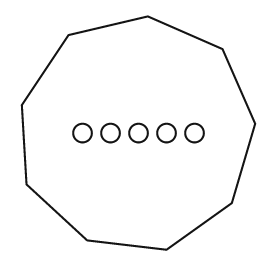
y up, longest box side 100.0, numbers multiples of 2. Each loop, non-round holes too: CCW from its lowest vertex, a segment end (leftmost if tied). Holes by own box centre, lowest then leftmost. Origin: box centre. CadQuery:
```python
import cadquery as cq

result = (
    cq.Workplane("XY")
    .moveTo(12.0, -50.0)
    .lineTo(40.0, -30.0)
    .lineTo(50.0, 4.0)
    .lineTo(36.0, 36.0)
    .lineTo(4.0, 50.0)
    .lineTo(-30.0, 42.0)
    .lineTo(-50.0, 12.0)
    .lineTo(-48.0, -22.0)
    .lineTo(-22.0, -46.0)
    .close()
    .moveTo(-24.0, 0.0)
    .circle(4.0)
    .moveTo(-12.0, 0.0)
    .circle(4.0)
    .moveTo(0.0, 0.0)
    .circle(4.0)
    .moveTo(12.0, 0.0)
    .circle(4.0)
    .moveTo(24.0, 0.0)
    .circle(4.0)
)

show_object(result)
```